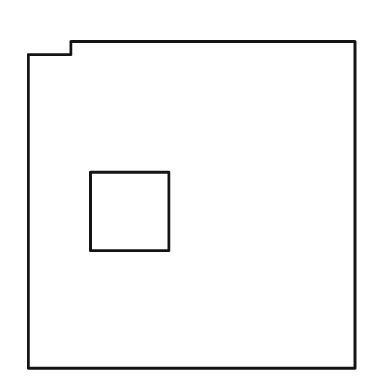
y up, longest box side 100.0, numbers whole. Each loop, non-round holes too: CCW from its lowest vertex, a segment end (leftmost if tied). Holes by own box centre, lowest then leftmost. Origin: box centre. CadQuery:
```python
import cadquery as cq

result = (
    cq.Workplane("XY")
    .moveTo(-50.0, -50.0)
    .lineTo(50.0, -50.0)
    .lineTo(50.0, 50.0)
    .lineTo(-37.0, 50.0)
    .lineTo(-37.0, 46.0)
    .lineTo(-50.0, 46.0)
    .close()
    .moveTo(-31.0, -14.0)
    .lineTo(-7.0, -14.0)
    .lineTo(-7.0, 10.0)
    .lineTo(-31.0, 10.0)
    .close()
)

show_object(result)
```